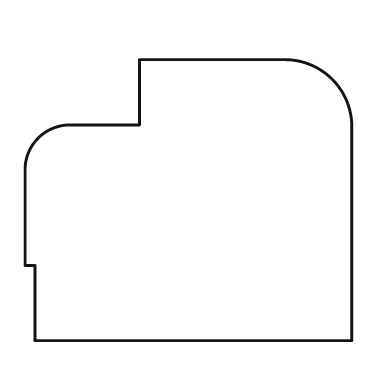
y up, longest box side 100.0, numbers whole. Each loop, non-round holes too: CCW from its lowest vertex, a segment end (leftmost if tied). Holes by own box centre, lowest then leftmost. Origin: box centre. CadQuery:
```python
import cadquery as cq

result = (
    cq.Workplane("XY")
    .moveTo(-47.0, -43.0)
    .lineTo(50.0, -43.0)
    .lineTo(50.0, 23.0)
    .threePointArc((44.0, 37.0), (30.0, 43.0))
    .lineTo(-15.0, 43.0)
    .lineTo(-15.0, 23.0)
    .lineTo(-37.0, 23.0)
    .threePointArc((-46.0, 19.0), (-50.0, 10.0))
    .lineTo(-50.0, -20.0)
    .lineTo(-47.0, -20.0)
    .close()
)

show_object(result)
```